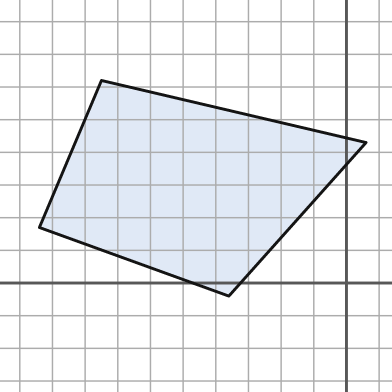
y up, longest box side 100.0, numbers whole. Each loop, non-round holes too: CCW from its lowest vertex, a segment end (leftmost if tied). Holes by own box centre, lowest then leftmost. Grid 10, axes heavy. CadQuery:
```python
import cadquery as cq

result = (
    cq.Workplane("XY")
    .moveTo(-36.0, -4.0)
    .lineTo(6.0, 43.0)
    .lineTo(-75.0, 62.0)
    .lineTo(-94.0, 17.0)
    .close()
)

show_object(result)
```